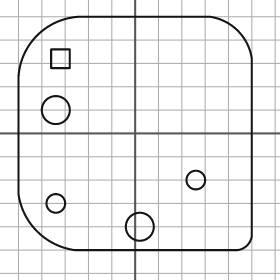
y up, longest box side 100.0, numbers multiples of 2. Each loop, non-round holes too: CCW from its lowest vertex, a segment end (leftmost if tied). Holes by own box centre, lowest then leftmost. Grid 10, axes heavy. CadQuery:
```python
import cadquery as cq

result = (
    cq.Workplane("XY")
    .moveTo(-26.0, -50.0)
    .lineTo(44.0, -50.0)
    .threePointArc((48.0, -48.0), (50.0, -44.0))
    .lineTo(50.0, 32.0)
    .threePointArc((44.0, 44.0), (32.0, 50.0))
    .lineTo(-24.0, 50.0)
    .threePointArc((-42.0, 42.0), (-50.0, 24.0))
    .lineTo(-50.0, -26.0)
    .threePointArc((-42.0, -42.0), (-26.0, -50.0))
    .close()
    .moveTo(2.0, -40.0)
    .circle(6.0)
    .moveTo(-34.0, -30.0)
    .circle(4.0)
    .moveTo(26.0, -20.0)
    .circle(4.0)
    .moveTo(-34.0, 10.0)
    .circle(6.0)
    .moveTo(-36.0, 28.0)
    .lineTo(-28.0, 28.0)
    .lineTo(-28.0, 36.0)
    .lineTo(-36.0, 36.0)
    .close()
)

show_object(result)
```